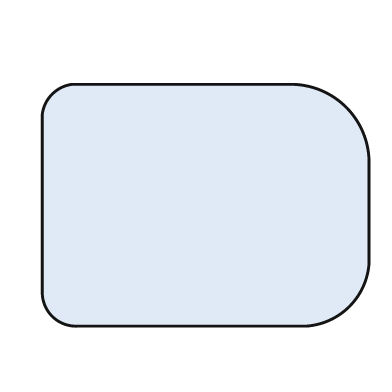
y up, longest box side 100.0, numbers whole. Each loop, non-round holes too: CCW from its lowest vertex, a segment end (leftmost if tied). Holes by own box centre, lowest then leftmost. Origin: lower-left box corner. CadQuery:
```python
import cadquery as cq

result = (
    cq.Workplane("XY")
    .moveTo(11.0, 0.0)
    .lineTo(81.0, 0.0)
    .threePointArc((94.0, 6.0), (100.0, 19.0))
    .lineTo(100.0, 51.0)
    .threePointArc((93.0, 67.0), (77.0, 74.0))
    .lineTo(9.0, 74.0)
    .threePointArc((3.0, 71.0), (0.0, 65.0))
    .lineTo(0.0, 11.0)
    .threePointArc((3.0, 3.0), (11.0, 0.0))
    .close()
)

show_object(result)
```